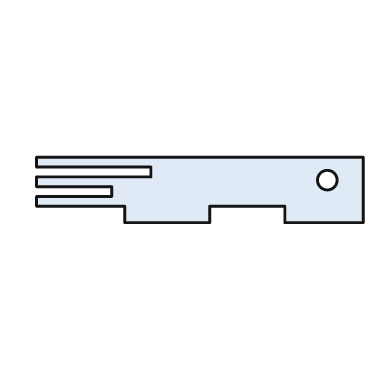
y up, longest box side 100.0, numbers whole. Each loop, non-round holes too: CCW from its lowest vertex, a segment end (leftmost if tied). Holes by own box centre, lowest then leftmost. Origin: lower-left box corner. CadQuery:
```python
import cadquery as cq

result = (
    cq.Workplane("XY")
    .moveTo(27.0, 0.0)
    .lineTo(53.0, 0.0)
    .lineTo(53.0, 5.0)
    .lineTo(76.0, 5.0)
    .lineTo(76.0, 0.0)
    .lineTo(100.0, 0.0)
    .lineTo(100.0, 20.0)
    .lineTo(0.0, 20.0)
    .lineTo(0.0, 17.0)
    .lineTo(35.0, 17.0)
    .lineTo(35.0, 14.0)
    .lineTo(0.0, 14.0)
    .lineTo(0.0, 11.0)
    .lineTo(23.0, 11.0)
    .lineTo(23.0, 8.0)
    .lineTo(0.0, 8.0)
    .lineTo(0.0, 5.0)
    .lineTo(27.0, 5.0)
    .close()
    .moveTo(89.0, 13.0)
    .circle(3.0)
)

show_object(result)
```